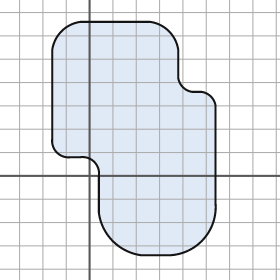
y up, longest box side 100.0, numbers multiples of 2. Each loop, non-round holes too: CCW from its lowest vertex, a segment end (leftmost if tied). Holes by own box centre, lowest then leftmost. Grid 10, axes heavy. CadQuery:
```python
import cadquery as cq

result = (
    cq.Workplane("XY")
    .moveTo(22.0, -34.0)
    .lineTo(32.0, -34.0)
    .threePointArc((48.0, -28.0), (54.0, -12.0))
    .lineTo(54.0, 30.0)
    .threePointArc((52.0, 34.0), (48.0, 36.0))
    .lineTo(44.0, 36.0)
    .threePointArc((40.0, 38.0), (38.0, 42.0))
    .lineTo(38.0, 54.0)
    .threePointArc((34.0, 62.0), (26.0, 66.0))
    .lineTo(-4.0, 66.0)
    .threePointArc((-12.0, 62.0), (-16.0, 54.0))
    .lineTo(-16.0, 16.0)
    .threePointArc((-14.0, 10.0), (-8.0, 8.0))
    .lineTo(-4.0, 8.0)
    .threePointArc((2.0, 6.0), (4.0, 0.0))
    .lineTo(4.0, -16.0)
    .threePointArc((10.0, -28.0), (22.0, -34.0))
    .close()
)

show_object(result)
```